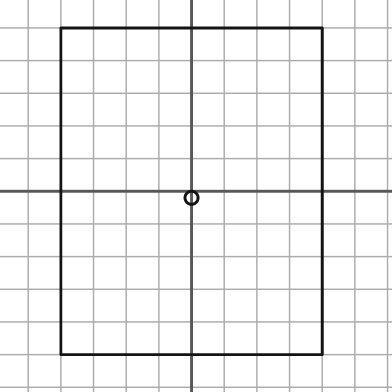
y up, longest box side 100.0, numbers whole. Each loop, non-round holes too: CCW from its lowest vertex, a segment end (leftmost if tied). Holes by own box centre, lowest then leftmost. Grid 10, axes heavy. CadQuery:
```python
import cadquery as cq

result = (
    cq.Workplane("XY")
    .moveTo(-40.0, -50.0)
    .lineTo(40.0, -50.0)
    .lineTo(40.0, 50.0)
    .lineTo(-40.0, 50.0)
    .close()
    .moveTo(0.0, -2.0)
    .circle(2.0)
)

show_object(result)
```